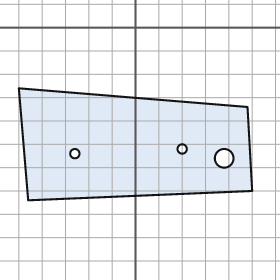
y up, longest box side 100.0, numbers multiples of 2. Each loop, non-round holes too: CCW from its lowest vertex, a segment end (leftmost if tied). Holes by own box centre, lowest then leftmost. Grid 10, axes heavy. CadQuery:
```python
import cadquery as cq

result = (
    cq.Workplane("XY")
    .moveTo(-46.0, -74.0)
    .lineTo(50.0, -70.0)
    .lineTo(48.0, -34.0)
    .lineTo(-50.0, -26.0)
    .close()
    .moveTo(38.0, -56.0)
    .circle(4.0)
    .moveTo(-26.0, -54.0)
    .circle(2.0)
    .moveTo(20.0, -52.0)
    .circle(2.0)
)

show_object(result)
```